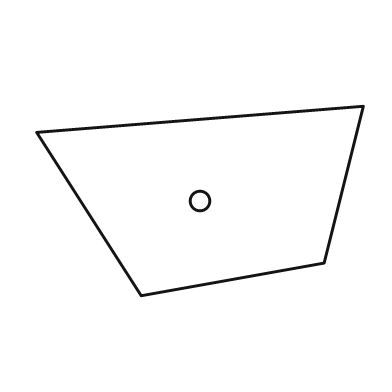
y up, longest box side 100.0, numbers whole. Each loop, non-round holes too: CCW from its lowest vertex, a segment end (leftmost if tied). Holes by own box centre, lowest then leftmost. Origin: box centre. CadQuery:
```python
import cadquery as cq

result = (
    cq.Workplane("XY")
    .moveTo(-18.0, -29.0)
    .lineTo(38.0, -19.0)
    .lineTo(50.0, 29.0)
    .lineTo(-50.0, 21.0)
    .close()
    .moveTo(0.0, 0.0)
    .circle(3.0)
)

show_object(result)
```